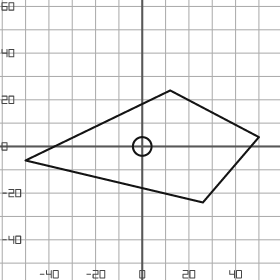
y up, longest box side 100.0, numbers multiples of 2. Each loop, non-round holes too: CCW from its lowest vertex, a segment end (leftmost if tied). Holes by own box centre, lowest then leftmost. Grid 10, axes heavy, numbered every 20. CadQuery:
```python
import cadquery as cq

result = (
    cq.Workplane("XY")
    .moveTo(26.0, -24.0)
    .lineTo(50.0, 4.0)
    .lineTo(12.0, 24.0)
    .lineTo(-50.0, -6.0)
    .close()
    .moveTo(0.0, 0.0)
    .circle(4.0)
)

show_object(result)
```